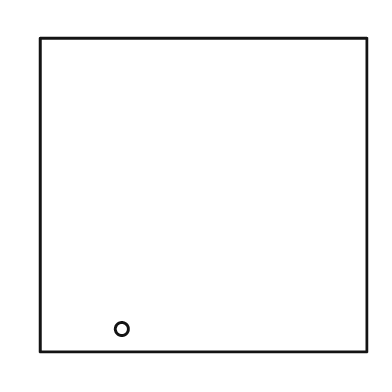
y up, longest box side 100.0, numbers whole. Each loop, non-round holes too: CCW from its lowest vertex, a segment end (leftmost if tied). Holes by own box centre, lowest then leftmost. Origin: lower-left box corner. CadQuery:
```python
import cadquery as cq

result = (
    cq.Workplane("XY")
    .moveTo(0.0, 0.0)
    .lineTo(100.0, 0.0)
    .lineTo(100.0, 96.0)
    .lineTo(0.0, 96.0)
    .close()
    .moveTo(25.0, 7.0)
    .circle(2.0)
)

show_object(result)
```